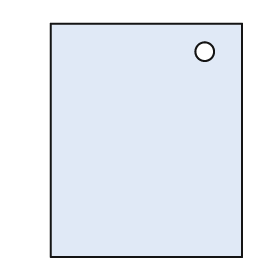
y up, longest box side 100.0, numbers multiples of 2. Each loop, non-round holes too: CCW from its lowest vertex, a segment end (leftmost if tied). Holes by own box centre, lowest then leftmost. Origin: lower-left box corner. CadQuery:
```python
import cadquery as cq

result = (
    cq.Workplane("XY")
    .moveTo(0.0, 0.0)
    .lineTo(82.0, 0.0)
    .lineTo(82.0, 100.0)
    .lineTo(0.0, 100.0)
    .close()
    .moveTo(66.0, 88.0)
    .circle(4.0)
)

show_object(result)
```